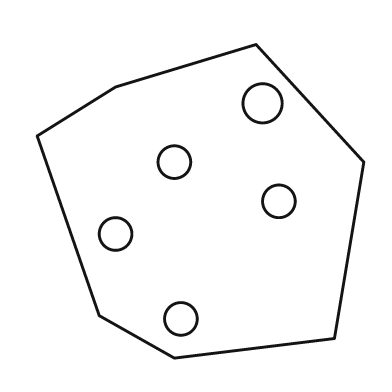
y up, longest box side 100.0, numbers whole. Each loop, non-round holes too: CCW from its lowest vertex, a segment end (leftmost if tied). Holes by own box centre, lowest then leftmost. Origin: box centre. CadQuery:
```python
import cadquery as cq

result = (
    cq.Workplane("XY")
    .moveTo(-8.0, -48.0)
    .lineTo(41.0, -42.0)
    .lineTo(50.0, 12.0)
    .lineTo(17.0, 48.0)
    .lineTo(-26.0, 35.0)
    .lineTo(-50.0, 20.0)
    .lineTo(-31.0, -35.0)
    .close()
    .moveTo(-6.0, -36.0)
    .circle(5.0)
    .moveTo(-26.0, -10.0)
    .circle(5.0)
    .moveTo(24.0, 0.0)
    .circle(5.0)
    .moveTo(-8.0, 12.0)
    .circle(5.0)
    .moveTo(19.0, 30.0)
    .circle(6.0)
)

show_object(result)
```